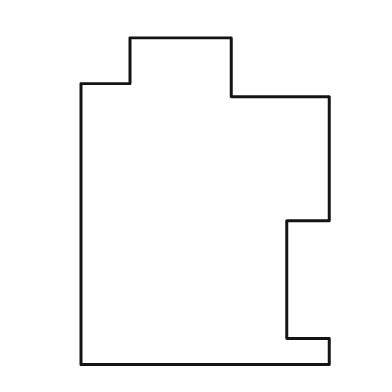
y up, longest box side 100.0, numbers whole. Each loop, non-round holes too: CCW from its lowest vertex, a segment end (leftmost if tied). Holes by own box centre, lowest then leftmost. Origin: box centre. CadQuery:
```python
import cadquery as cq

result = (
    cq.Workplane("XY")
    .moveTo(-38.0, -50.0)
    .lineTo(38.0, -50.0)
    .lineTo(38.0, -42.0)
    .lineTo(25.0, -42.0)
    .lineTo(25.0, -6.0)
    .lineTo(38.0, -6.0)
    .lineTo(38.0, 32.0)
    .lineTo(8.0, 32.0)
    .lineTo(8.0, 50.0)
    .lineTo(-23.0, 50.0)
    .lineTo(-23.0, 36.0)
    .lineTo(-38.0, 36.0)
    .close()
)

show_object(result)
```